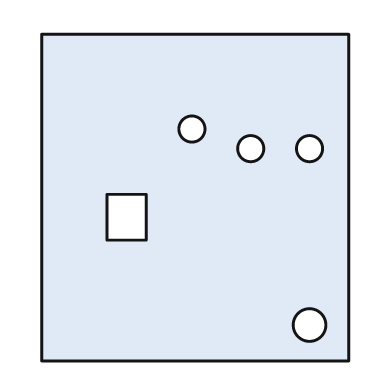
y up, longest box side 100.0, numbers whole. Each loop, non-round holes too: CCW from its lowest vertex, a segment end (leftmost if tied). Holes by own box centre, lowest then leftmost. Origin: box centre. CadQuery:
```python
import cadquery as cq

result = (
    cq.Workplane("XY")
    .moveTo(-47.0, -50.0)
    .lineTo(47.0, -50.0)
    .lineTo(47.0, 50.0)
    .lineTo(-47.0, 50.0)
    .close()
    .moveTo(35.0, -39.0)
    .circle(5.0)
    .moveTo(-27.0, -13.0)
    .lineTo(-15.0, -13.0)
    .lineTo(-15.0, 1.0)
    .lineTo(-27.0, 1.0)
    .close()
    .moveTo(17.0, 15.0)
    .circle(4.0)
    .moveTo(35.0, 15.0)
    .circle(4.0)
    .moveTo(-1.0, 21.0)
    .circle(4.0)
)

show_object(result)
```